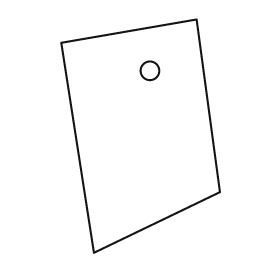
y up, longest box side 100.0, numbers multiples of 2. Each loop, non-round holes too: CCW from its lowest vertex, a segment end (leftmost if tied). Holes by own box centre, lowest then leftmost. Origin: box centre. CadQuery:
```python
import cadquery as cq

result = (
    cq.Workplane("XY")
    .moveTo(-20.0, -50.0)
    .lineTo(34.0, -24.0)
    .lineTo(24.0, 50.0)
    .lineTo(-34.0, 40.0)
    .close()
    .moveTo(4.0, 28.0)
    .circle(4.0)
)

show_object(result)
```